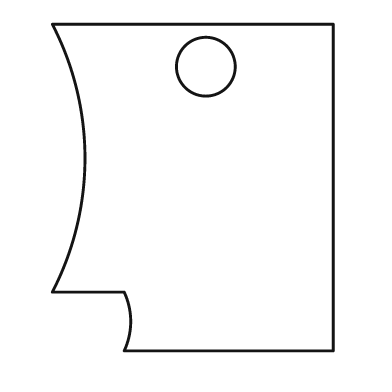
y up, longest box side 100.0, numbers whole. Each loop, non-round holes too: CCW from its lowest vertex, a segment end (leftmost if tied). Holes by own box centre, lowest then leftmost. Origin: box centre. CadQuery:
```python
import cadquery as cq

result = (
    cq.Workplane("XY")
    .moveTo(-21.0, -50.0)
    .lineTo(43.0, -50.0)
    .lineTo(43.0, 50.0)
    .lineTo(-43.0, 50.0)
    .threePointArc((-33.0, 9.0), (-43.0, -32.0))
    .lineTo(-21.0, -32.0)
    .threePointArc((-19.0, -41.0), (-21.0, -50.0))
    .close()
    .moveTo(4.0, 37.0)
    .circle(9.0)
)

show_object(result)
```